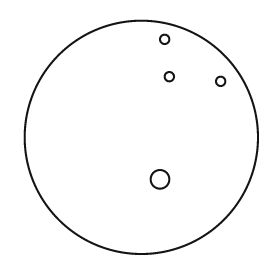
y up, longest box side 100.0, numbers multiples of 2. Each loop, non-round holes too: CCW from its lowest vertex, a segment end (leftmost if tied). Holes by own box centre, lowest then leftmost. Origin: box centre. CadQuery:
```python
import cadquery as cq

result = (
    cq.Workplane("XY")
    .moveTo(0.0, 0.0)
    .circle(50.0)
    .moveTo(8.0, -18.0)
    .circle(4.0)
    .moveTo(34.0, 24.0)
    .circle(2.0)
    .moveTo(12.0, 26.0)
    .circle(2.0)
    .moveTo(10.0, 42.0)
    .circle(2.0)
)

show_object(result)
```